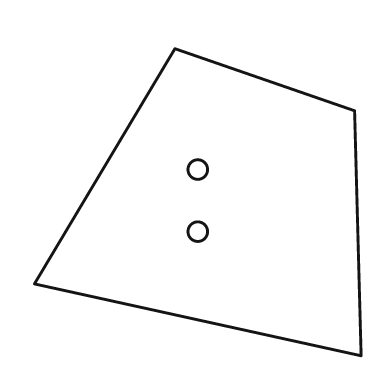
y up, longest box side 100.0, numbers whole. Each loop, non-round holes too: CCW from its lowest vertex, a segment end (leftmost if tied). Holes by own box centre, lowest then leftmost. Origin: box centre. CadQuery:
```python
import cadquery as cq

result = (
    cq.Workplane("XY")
    .moveTo(50.0, -47.0)
    .lineTo(48.0, 28.0)
    .lineTo(-7.0, 47.0)
    .lineTo(-50.0, -25.0)
    .close()
    .moveTo(0.0, -9.0)
    .circle(3.0)
    .moveTo(0.0, 10.0)
    .circle(3.0)
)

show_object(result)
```